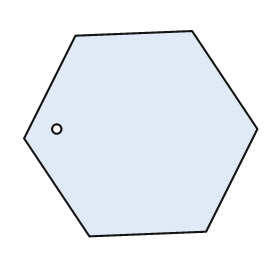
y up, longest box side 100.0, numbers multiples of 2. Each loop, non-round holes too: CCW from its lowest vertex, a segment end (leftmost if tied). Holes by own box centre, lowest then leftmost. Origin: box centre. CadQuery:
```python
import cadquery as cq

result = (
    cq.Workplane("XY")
    .moveTo(-22.0, -44.0)
    .lineTo(28.0, -42.0)
    .lineTo(50.0, 2.0)
    .lineTo(22.0, 44.0)
    .lineTo(-28.0, 42.0)
    .lineTo(-50.0, -2.0)
    .close()
    .moveTo(-36.0, 2.0)
    .circle(2.0)
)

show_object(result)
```